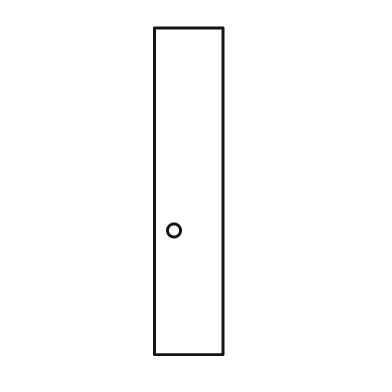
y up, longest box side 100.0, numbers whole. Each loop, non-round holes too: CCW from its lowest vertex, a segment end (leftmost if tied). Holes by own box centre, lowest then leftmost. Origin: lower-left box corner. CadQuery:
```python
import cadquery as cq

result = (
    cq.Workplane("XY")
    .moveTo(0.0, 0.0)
    .lineTo(21.0, 0.0)
    .lineTo(21.0, 100.0)
    .lineTo(0.0, 100.0)
    .close()
    .moveTo(6.0, 38.0)
    .circle(2.0)
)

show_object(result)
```